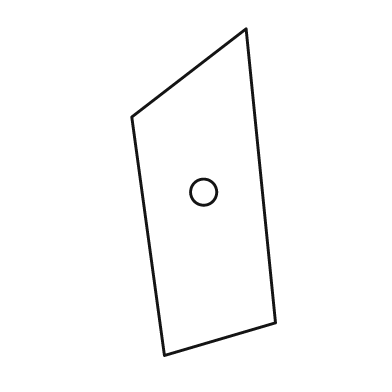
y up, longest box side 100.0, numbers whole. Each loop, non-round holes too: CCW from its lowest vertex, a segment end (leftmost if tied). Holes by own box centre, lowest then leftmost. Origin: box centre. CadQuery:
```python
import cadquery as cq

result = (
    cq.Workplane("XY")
    .moveTo(-12.0, -50.0)
    .lineTo(22.0, -40.0)
    .lineTo(13.0, 50.0)
    .lineTo(-22.0, 23.0)
    .close()
    .moveTo(0.0, 0.0)
    .circle(4.0)
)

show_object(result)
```